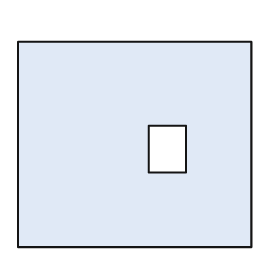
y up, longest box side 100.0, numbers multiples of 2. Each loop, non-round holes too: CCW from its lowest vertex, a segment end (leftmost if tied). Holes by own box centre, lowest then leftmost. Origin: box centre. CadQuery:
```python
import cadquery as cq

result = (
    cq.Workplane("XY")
    .moveTo(-50.0, -44.0)
    .lineTo(50.0, -44.0)
    .lineTo(50.0, 44.0)
    .lineTo(-50.0, 44.0)
    .close()
    .moveTo(6.0, -12.0)
    .lineTo(22.0, -12.0)
    .lineTo(22.0, 8.0)
    .lineTo(6.0, 8.0)
    .close()
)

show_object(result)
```